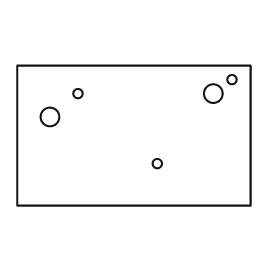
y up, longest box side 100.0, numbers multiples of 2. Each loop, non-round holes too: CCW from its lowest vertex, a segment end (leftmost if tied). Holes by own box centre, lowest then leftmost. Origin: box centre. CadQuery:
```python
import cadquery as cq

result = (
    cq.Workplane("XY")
    .moveTo(-50.0, -30.0)
    .lineTo(50.0, -30.0)
    .lineTo(50.0, 30.0)
    .lineTo(-50.0, 30.0)
    .close()
    .moveTo(10.0, -12.0)
    .circle(2.0)
    .moveTo(-36.0, 8.0)
    .circle(4.0)
    .moveTo(-24.0, 18.0)
    .circle(2.0)
    .moveTo(34.0, 18.0)
    .circle(4.0)
    .moveTo(42.0, 24.0)
    .circle(2.0)
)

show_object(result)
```